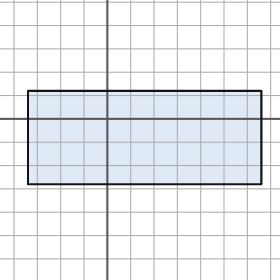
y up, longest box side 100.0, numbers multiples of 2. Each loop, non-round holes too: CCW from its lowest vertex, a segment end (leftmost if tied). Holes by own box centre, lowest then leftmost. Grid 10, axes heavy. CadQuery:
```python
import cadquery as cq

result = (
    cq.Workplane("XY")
    .moveTo(-34.0, -28.0)
    .lineTo(66.0, -28.0)
    .lineTo(66.0, 12.0)
    .lineTo(-34.0, 12.0)
    .close()
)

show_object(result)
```